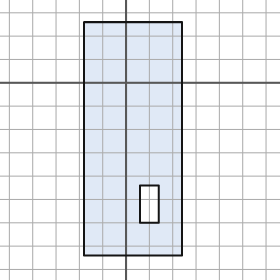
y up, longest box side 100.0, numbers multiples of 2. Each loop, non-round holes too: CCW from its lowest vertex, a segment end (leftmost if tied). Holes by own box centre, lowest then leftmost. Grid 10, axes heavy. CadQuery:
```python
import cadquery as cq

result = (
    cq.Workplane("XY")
    .moveTo(-18.0, -74.0)
    .lineTo(24.0, -74.0)
    .lineTo(24.0, 26.0)
    .lineTo(-18.0, 26.0)
    .close()
    .moveTo(6.0, -60.0)
    .lineTo(14.0, -60.0)
    .lineTo(14.0, -44.0)
    .lineTo(6.0, -44.0)
    .close()
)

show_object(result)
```